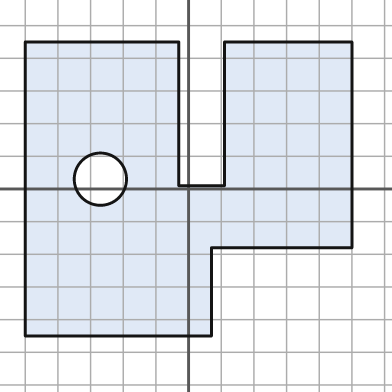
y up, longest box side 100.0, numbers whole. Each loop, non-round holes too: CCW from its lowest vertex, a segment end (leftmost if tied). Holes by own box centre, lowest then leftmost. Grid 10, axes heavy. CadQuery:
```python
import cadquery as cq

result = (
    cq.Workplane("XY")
    .moveTo(-50.0, -45.0)
    .lineTo(7.0, -45.0)
    .lineTo(7.0, -18.0)
    .lineTo(50.0, -18.0)
    .lineTo(50.0, 45.0)
    .lineTo(11.0, 45.0)
    .lineTo(11.0, 1.0)
    .lineTo(-3.0, 1.0)
    .lineTo(-3.0, 45.0)
    .lineTo(-50.0, 45.0)
    .close()
    .moveTo(-27.0, 3.0)
    .circle(8.0)
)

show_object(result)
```